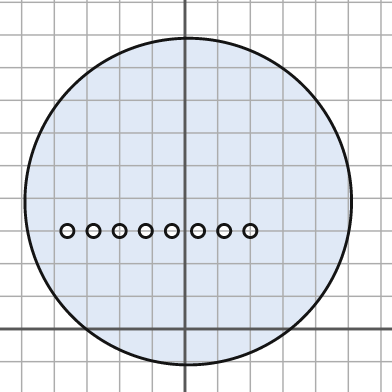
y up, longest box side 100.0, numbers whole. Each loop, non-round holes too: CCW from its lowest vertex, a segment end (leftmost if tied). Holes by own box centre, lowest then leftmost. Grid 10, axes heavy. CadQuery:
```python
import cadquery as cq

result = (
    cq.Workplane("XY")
    .moveTo(1.0, 39.0)
    .circle(50.0)
    .moveTo(-36.0, 30.0)
    .circle(2.0)
    .moveTo(-28.0, 30.0)
    .circle(2.0)
    .moveTo(-20.0, 30.0)
    .circle(2.0)
    .moveTo(-12.0, 30.0)
    .circle(2.0)
    .moveTo(-4.0, 30.0)
    .circle(2.0)
    .moveTo(4.0, 30.0)
    .circle(2.0)
    .moveTo(12.0, 30.0)
    .circle(2.0)
    .moveTo(20.0, 30.0)
    .circle(2.0)
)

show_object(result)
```